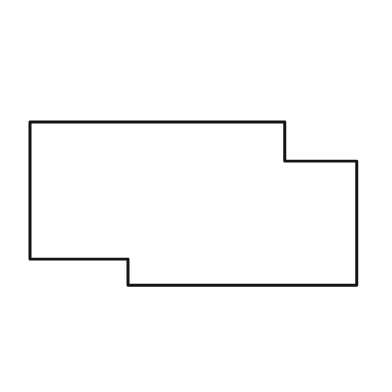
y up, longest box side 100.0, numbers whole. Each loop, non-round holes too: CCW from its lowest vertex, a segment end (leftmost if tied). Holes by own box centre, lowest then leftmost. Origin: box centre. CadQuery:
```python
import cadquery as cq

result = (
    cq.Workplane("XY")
    .moveTo(-20.0, -25.0)
    .lineTo(50.0, -25.0)
    .lineTo(50.0, 13.0)
    .lineTo(28.0, 13.0)
    .lineTo(28.0, 25.0)
    .lineTo(-50.0, 25.0)
    .lineTo(-50.0, -17.0)
    .lineTo(-20.0, -17.0)
    .close()
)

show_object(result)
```